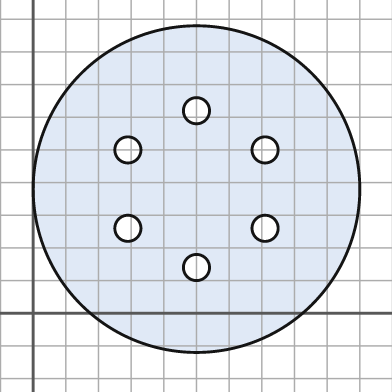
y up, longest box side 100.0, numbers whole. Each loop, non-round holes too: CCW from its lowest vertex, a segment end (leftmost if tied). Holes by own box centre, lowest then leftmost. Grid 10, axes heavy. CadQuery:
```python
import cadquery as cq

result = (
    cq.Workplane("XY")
    .moveTo(50.0, 38.0)
    .circle(50.0)
    .moveTo(50.0, 14.0)
    .circle(4.0)
    .moveTo(29.0, 26.0)
    .circle(4.0)
    .moveTo(71.0, 26.0)
    .circle(4.0)
    .moveTo(29.0, 50.0)
    .circle(4.0)
    .moveTo(71.0, 50.0)
    .circle(4.0)
    .moveTo(50.0, 62.0)
    .circle(4.0)
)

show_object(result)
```